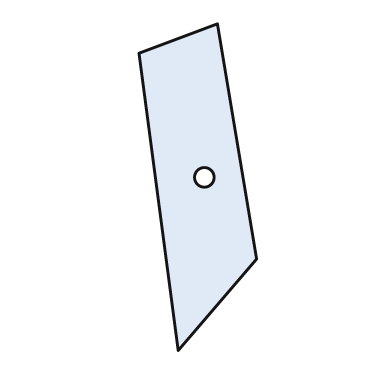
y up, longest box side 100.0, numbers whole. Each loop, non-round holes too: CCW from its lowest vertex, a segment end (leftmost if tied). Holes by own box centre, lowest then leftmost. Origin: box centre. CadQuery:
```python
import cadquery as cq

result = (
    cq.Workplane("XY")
    .moveTo(-6.0, -50.0)
    .lineTo(18.0, -22.0)
    .lineTo(6.0, 50.0)
    .lineTo(-18.0, 41.0)
    .close()
    .moveTo(2.0, 3.0)
    .circle(3.0)
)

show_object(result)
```